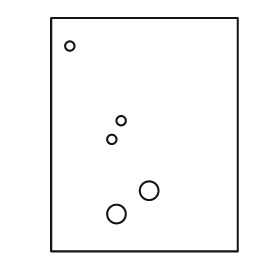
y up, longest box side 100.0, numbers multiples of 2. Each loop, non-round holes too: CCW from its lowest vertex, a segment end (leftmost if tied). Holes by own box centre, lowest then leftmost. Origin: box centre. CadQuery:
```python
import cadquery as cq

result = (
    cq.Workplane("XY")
    .moveTo(-40.0, -50.0)
    .lineTo(40.0, -50.0)
    .lineTo(40.0, 50.0)
    .lineTo(-40.0, 50.0)
    .close()
    .moveTo(-12.0, -34.0)
    .circle(4.0)
    .moveTo(2.0, -24.0)
    .circle(4.0)
    .moveTo(-14.0, -2.0)
    .circle(2.0)
    .moveTo(-10.0, 6.0)
    .circle(2.0)
    .moveTo(-32.0, 38.0)
    .circle(2.0)
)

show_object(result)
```